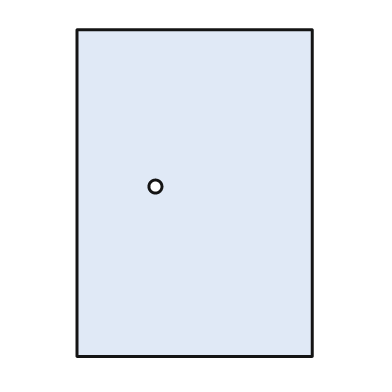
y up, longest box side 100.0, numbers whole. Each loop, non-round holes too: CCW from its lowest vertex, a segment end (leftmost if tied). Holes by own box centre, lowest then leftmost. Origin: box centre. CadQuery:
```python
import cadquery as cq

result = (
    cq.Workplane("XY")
    .moveTo(-36.0, -50.0)
    .lineTo(36.0, -50.0)
    .lineTo(36.0, 50.0)
    .lineTo(-36.0, 50.0)
    .close()
    .moveTo(-12.0, 2.0)
    .circle(2.0)
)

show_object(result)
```